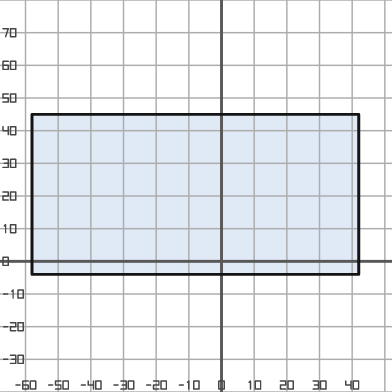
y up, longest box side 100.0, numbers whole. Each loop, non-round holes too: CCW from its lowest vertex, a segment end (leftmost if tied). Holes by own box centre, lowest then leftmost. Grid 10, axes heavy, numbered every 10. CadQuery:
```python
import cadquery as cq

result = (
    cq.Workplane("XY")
    .moveTo(-58.0, -4.0)
    .lineTo(42.0, -4.0)
    .lineTo(42.0, 45.0)
    .lineTo(-58.0, 45.0)
    .close()
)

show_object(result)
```